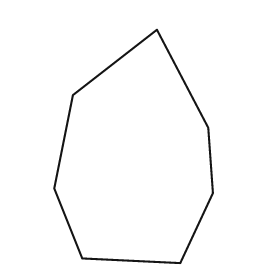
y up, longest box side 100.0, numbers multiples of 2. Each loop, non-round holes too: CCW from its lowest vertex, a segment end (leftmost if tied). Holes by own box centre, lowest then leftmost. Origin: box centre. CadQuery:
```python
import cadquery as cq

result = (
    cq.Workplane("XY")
    .moveTo(20.0, -50.0)
    .lineTo(34.0, -20.0)
    .lineTo(32.0, 8.0)
    .lineTo(10.0, 50.0)
    .lineTo(-26.0, 22.0)
    .lineTo(-34.0, -18.0)
    .lineTo(-22.0, -48.0)
    .close()
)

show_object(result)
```